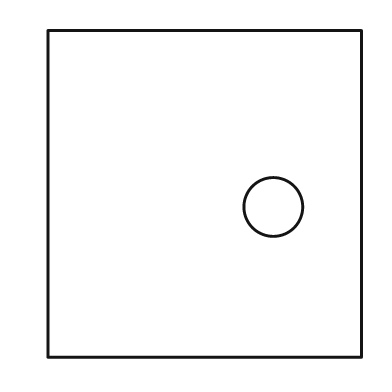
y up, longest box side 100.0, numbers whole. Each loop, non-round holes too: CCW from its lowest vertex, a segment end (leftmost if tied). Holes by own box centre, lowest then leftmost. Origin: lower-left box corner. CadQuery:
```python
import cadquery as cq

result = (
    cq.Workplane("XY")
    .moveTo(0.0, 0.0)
    .lineTo(96.0, 0.0)
    .lineTo(96.0, 100.0)
    .lineTo(0.0, 100.0)
    .close()
    .moveTo(69.0, 46.0)
    .circle(9.0)
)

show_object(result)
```